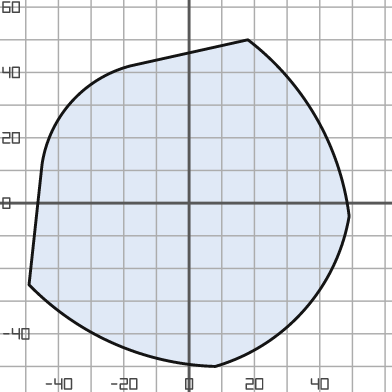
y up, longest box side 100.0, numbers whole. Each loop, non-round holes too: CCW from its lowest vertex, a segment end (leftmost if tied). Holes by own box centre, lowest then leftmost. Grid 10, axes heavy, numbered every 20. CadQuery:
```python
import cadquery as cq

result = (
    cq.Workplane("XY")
    .moveTo(8.0, -50.0)
    .threePointArc((35.0, -33.0), (49.0, -4.0))
    .threePointArc((39.0, 26.0), (18.0, 50.0))
    .lineTo(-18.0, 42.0)
    .threePointArc((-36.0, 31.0), (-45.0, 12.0))
    .lineTo(-49.0, -25.0)
    .threePointArc((-23.0, -43.0), (8.0, -50.0))
    .close()
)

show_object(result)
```